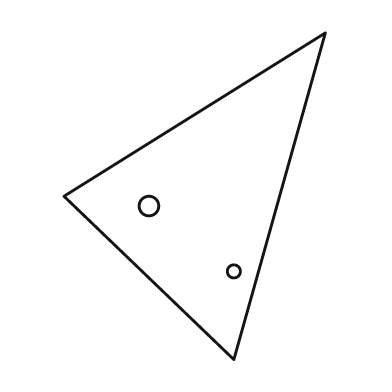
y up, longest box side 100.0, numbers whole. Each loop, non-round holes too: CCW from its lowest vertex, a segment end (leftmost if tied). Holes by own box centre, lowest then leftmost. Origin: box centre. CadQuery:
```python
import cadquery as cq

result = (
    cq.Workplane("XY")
    .moveTo(12.0, -50.0)
    .lineTo(40.0, 50.0)
    .lineTo(-40.0, 0.0)
    .close()
    .moveTo(12.0, -23.0)
    .circle(2.0)
    .moveTo(-14.0, -3.0)
    .circle(3.0)
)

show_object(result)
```